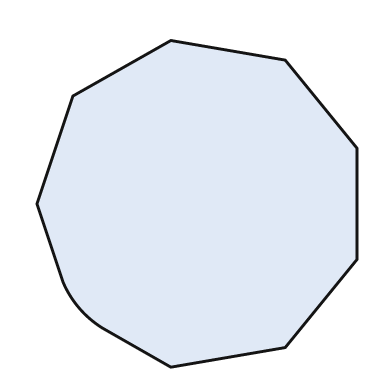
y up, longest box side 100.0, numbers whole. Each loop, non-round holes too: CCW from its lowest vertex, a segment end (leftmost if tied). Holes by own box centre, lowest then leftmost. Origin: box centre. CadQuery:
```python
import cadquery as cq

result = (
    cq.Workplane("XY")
    .moveTo(-8.0, -50.0)
    .lineTo(27.0, -44.0)
    .lineTo(49.0, -17.0)
    .lineTo(49.0, 17.0)
    .lineTo(27.0, 44.0)
    .lineTo(-8.0, 50.0)
    .lineTo(-38.0, 33.0)
    .lineTo(-49.0, 0.0)
    .lineTo(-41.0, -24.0)
    .threePointArc((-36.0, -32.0), (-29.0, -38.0))
    .close()
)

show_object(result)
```